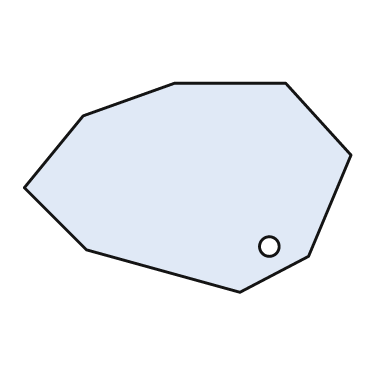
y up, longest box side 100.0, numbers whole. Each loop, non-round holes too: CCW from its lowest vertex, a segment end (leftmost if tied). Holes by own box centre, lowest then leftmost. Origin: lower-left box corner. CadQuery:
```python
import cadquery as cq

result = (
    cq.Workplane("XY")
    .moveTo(66.0, 0.0)
    .lineTo(87.0, 11.0)
    .lineTo(100.0, 42.0)
    .lineTo(80.0, 64.0)
    .lineTo(46.0, 64.0)
    .lineTo(18.0, 54.0)
    .lineTo(0.0, 32.0)
    .lineTo(19.0, 13.0)
    .close()
    .moveTo(75.0, 14.0)
    .circle(3.0)
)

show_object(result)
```